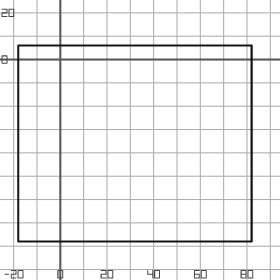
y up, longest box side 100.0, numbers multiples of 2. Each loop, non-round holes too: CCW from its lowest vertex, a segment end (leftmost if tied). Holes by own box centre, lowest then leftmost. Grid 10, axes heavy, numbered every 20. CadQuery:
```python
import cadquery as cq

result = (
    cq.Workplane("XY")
    .moveTo(-18.0, -78.0)
    .lineTo(82.0, -78.0)
    .lineTo(82.0, 6.0)
    .lineTo(-18.0, 6.0)
    .close()
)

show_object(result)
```